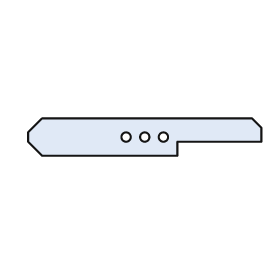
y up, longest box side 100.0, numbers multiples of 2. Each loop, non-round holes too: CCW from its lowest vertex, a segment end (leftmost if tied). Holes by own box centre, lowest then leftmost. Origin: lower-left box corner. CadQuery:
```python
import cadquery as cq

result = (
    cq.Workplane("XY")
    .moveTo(6.0, 0.0)
    .lineTo(64.0, 0.0)
    .lineTo(64.0, 6.0)
    .lineTo(100.0, 6.0)
    .lineTo(100.0, 12.0)
    .lineTo(96.0, 16.0)
    .lineTo(6.0, 16.0)
    .lineTo(0.0, 10.0)
    .lineTo(0.0, 6.0)
    .close()
    .moveTo(42.0, 8.0)
    .circle(2.0)
    .moveTo(50.0, 8.0)
    .circle(2.0)
    .moveTo(58.0, 8.0)
    .circle(2.0)
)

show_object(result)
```